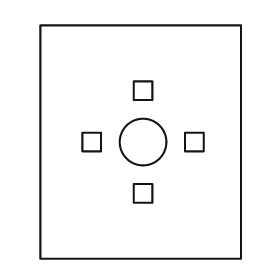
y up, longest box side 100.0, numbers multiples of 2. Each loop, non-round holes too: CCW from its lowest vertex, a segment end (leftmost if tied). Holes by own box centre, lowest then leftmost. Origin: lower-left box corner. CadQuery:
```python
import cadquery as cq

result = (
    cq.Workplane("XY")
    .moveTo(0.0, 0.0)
    .lineTo(86.0, 0.0)
    .lineTo(86.0, 100.0)
    .lineTo(0.0, 100.0)
    .close()
    .moveTo(40.0, 24.0)
    .lineTo(48.0, 24.0)
    .lineTo(48.0, 32.0)
    .lineTo(40.0, 32.0)
    .close()
    .moveTo(18.0, 46.0)
    .lineTo(26.0, 46.0)
    .lineTo(26.0, 54.0)
    .lineTo(18.0, 54.0)
    .close()
    .moveTo(44.0, 50.0)
    .circle(10.0)
    .moveTo(62.0, 46.0)
    .lineTo(70.0, 46.0)
    .lineTo(70.0, 54.0)
    .lineTo(62.0, 54.0)
    .close()
    .moveTo(40.0, 68.0)
    .lineTo(48.0, 68.0)
    .lineTo(48.0, 76.0)
    .lineTo(40.0, 76.0)
    .close()
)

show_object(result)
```